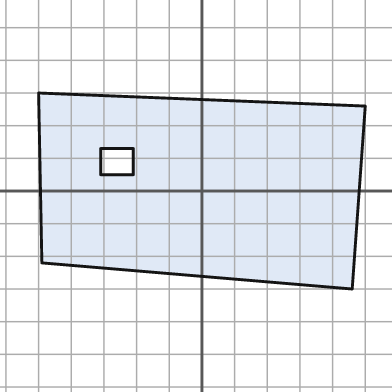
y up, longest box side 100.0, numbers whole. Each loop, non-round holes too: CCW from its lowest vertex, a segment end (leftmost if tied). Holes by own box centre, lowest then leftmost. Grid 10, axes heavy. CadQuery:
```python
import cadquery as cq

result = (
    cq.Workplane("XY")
    .moveTo(46.0, -30.0)
    .lineTo(50.0, 26.0)
    .lineTo(-50.0, 30.0)
    .lineTo(-49.0, -22.0)
    .close()
    .moveTo(-31.0, 5.0)
    .lineTo(-21.0, 5.0)
    .lineTo(-21.0, 13.0)
    .lineTo(-31.0, 13.0)
    .close()
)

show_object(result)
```